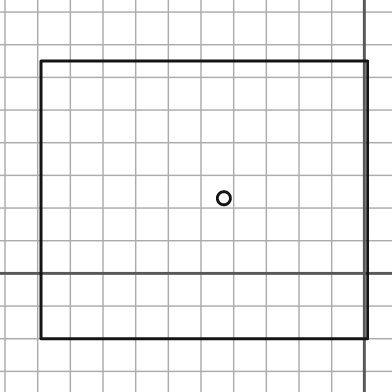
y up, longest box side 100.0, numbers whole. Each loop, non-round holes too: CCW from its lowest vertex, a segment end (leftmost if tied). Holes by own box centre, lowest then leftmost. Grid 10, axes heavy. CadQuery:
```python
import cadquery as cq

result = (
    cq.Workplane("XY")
    .moveTo(-99.0, -20.0)
    .lineTo(1.0, -20.0)
    .lineTo(1.0, 65.0)
    .lineTo(-99.0, 65.0)
    .close()
    .moveTo(-43.0, 23.0)
    .circle(2.0)
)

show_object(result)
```